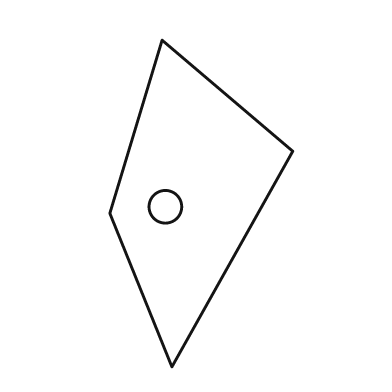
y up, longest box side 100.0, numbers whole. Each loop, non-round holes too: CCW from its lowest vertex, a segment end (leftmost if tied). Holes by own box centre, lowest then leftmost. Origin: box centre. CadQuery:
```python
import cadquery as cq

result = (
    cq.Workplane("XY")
    .moveTo(-9.0, -50.0)
    .lineTo(28.0, 16.0)
    .lineTo(-12.0, 50.0)
    .lineTo(-28.0, -3.0)
    .close()
    .moveTo(-11.0, -1.0)
    .circle(5.0)
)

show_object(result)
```